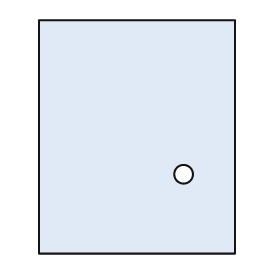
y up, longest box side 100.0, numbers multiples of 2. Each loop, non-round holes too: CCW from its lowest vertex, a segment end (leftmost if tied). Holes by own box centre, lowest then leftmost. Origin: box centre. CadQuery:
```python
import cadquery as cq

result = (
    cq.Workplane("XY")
    .moveTo(-42.0, -50.0)
    .lineTo(42.0, -50.0)
    .lineTo(42.0, 50.0)
    .lineTo(-42.0, 50.0)
    .close()
    .moveTo(20.0, -16.0)
    .circle(4.0)
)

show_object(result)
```